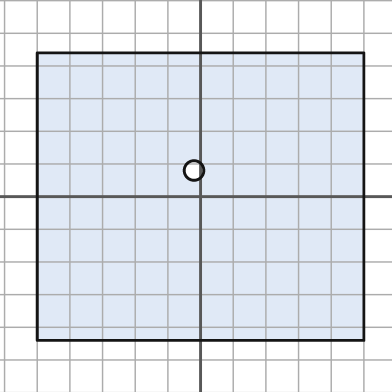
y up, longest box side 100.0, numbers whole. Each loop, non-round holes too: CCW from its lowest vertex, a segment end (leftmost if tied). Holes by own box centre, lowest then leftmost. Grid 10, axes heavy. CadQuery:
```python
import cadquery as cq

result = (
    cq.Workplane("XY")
    .moveTo(-50.0, -44.0)
    .lineTo(50.0, -44.0)
    .lineTo(50.0, 44.0)
    .lineTo(-50.0, 44.0)
    .close()
    .moveTo(-2.0, 8.0)
    .circle(3.0)
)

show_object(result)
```